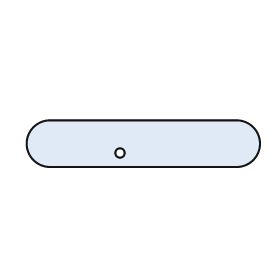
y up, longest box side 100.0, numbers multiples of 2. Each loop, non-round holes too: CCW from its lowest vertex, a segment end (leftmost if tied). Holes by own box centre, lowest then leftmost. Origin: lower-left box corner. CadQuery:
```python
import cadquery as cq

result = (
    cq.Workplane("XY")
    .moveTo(10.0, 0.0)
    .lineTo(90.0, 0.0)
    .threePointArc((100.0, 10.0), (90.0, 20.0))
    .lineTo(10.0, 20.0)
    .threePointArc((0.0, 10.0), (10.0, 0.0))
    .close()
    .moveTo(40.0, 6.0)
    .circle(2.0)
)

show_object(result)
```